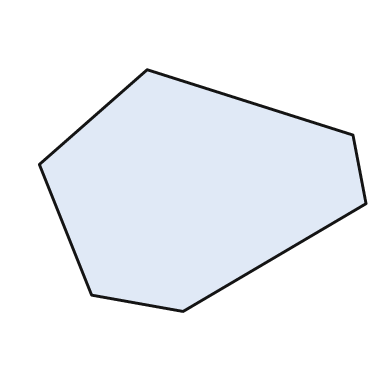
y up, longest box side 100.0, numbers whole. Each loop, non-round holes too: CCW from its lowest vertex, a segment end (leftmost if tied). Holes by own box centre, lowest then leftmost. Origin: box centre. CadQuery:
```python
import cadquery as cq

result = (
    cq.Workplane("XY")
    .moveTo(-6.0, -37.0)
    .lineTo(50.0, -4.0)
    .lineTo(46.0, 17.0)
    .lineTo(-17.0, 37.0)
    .lineTo(-50.0, 8.0)
    .lineTo(-34.0, -32.0)
    .close()
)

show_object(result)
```